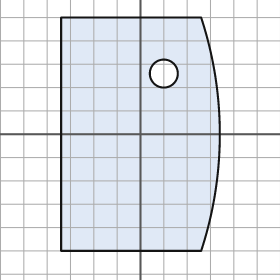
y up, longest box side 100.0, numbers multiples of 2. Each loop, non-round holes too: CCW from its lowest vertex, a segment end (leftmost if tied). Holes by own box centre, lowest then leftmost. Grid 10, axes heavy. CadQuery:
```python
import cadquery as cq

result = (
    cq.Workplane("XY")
    .moveTo(-34.0, -50.0)
    .lineTo(26.0, -50.0)
    .threePointArc((34.0, 0.0), (26.0, 50.0))
    .lineTo(-34.0, 50.0)
    .close()
    .moveTo(10.0, 26.0)
    .circle(6.0)
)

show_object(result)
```